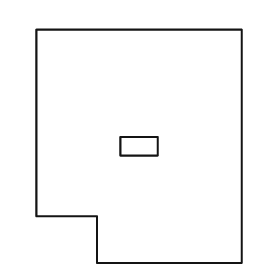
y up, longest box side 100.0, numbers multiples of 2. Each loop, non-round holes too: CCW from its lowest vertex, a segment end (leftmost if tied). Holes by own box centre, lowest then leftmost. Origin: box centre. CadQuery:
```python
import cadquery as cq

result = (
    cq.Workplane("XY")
    .moveTo(-18.0, -50.0)
    .lineTo(44.0, -50.0)
    .lineTo(44.0, 50.0)
    .lineTo(-44.0, 50.0)
    .lineTo(-44.0, -30.0)
    .lineTo(-18.0, -30.0)
    .close()
    .moveTo(-8.0, -4.0)
    .lineTo(8.0, -4.0)
    .lineTo(8.0, 4.0)
    .lineTo(-8.0, 4.0)
    .close()
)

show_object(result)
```